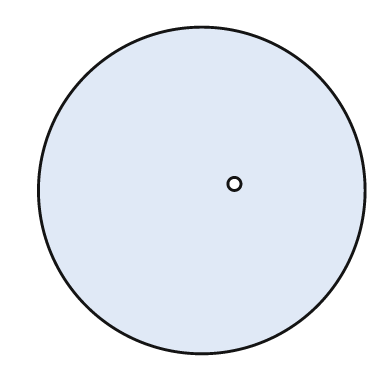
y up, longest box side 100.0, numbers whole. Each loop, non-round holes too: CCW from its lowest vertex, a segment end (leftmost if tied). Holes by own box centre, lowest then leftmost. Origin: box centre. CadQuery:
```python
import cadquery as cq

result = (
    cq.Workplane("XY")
    .moveTo(0.0, 0.0)
    .circle(50.0)
    .moveTo(10.0, 2.0)
    .circle(2.0)
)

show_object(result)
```